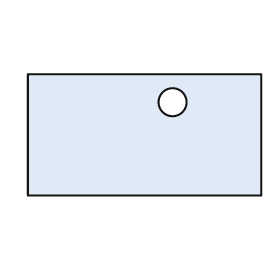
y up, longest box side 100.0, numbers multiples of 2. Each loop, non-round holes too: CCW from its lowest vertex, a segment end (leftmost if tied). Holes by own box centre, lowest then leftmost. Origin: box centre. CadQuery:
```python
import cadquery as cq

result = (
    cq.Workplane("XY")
    .moveTo(-50.0, -26.0)
    .lineTo(50.0, -26.0)
    .lineTo(50.0, 26.0)
    .lineTo(-50.0, 26.0)
    .close()
    .moveTo(12.0, 14.0)
    .circle(6.0)
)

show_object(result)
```